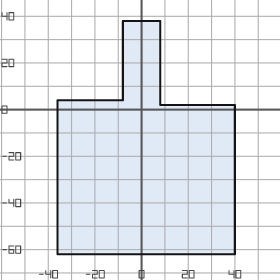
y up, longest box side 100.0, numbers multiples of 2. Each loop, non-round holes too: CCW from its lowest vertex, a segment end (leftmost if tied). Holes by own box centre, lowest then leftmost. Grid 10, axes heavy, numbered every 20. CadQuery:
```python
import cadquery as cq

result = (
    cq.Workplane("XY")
    .moveTo(-36.0, -62.0)
    .lineTo(40.0, -62.0)
    .lineTo(40.0, 2.0)
    .lineTo(8.0, 2.0)
    .lineTo(8.0, 38.0)
    .lineTo(-8.0, 38.0)
    .lineTo(-8.0, 4.0)
    .lineTo(-36.0, 4.0)
    .close()
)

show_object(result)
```